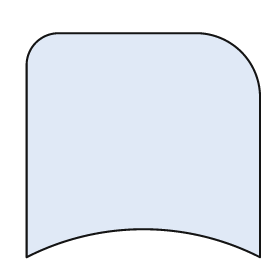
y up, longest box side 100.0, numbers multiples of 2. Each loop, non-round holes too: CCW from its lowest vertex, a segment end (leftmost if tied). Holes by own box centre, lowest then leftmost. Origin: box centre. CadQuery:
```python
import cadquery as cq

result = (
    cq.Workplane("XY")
    .moveTo(-50.0, -48.0)
    .threePointArc((0.0, -36.0), (50.0, -48.0))
    .lineTo(50.0, 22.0)
    .threePointArc((42.0, 40.0), (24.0, 48.0))
    .lineTo(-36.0, 48.0)
    .threePointArc((-46.0, 44.0), (-50.0, 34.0))
    .close()
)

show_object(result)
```